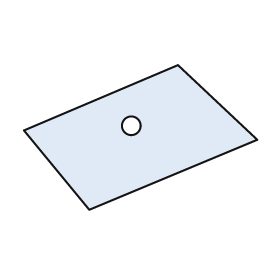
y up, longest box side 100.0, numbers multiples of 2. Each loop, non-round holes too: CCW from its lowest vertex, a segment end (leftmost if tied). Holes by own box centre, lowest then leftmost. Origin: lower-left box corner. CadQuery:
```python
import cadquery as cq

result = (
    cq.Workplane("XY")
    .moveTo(28.0, 0.0)
    .lineTo(100.0, 30.0)
    .lineTo(66.0, 62.0)
    .lineTo(0.0, 34.0)
    .close()
    .moveTo(46.0, 36.0)
    .circle(4.0)
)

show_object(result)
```